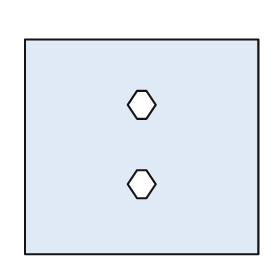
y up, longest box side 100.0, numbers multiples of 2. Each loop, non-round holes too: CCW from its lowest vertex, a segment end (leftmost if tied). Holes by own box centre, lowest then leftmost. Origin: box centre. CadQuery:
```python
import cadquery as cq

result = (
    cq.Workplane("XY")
    .moveTo(-50.0, -46.0)
    .lineTo(50.0, -46.0)
    .lineTo(50.0, 46.0)
    .lineTo(-50.0, 46.0)
    .close()
    .moveTo(-2.0, -22.0)
    .lineTo(2.0, -22.0)
    .lineTo(6.0, -16.0)
    .lineTo(2.0, -10.0)
    .lineTo(-2.0, -10.0)
    .lineTo(-6.0, -16.0)
    .close()
    .moveTo(-2.0, 12.0)
    .lineTo(2.0, 12.0)
    .lineTo(6.0, 18.0)
    .lineTo(2.0, 24.0)
    .lineTo(-2.0, 24.0)
    .lineTo(-6.0, 18.0)
    .close()
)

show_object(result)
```